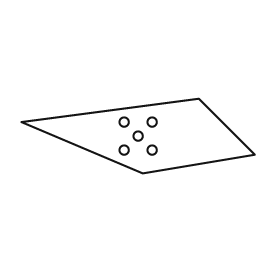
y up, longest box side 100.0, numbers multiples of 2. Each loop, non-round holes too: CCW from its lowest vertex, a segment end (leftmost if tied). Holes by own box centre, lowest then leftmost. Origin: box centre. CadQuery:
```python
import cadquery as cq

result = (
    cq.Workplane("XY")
    .moveTo(2.0, -16.0)
    .lineTo(50.0, -8.0)
    .lineTo(26.0, 16.0)
    .lineTo(-50.0, 6.0)
    .close()
    .moveTo(-6.0, -6.0)
    .circle(2.0)
    .moveTo(6.0, -6.0)
    .circle(2.0)
    .moveTo(0.0, 0.0)
    .circle(2.0)
    .moveTo(-6.0, 6.0)
    .circle(2.0)
    .moveTo(6.0, 6.0)
    .circle(2.0)
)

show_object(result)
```